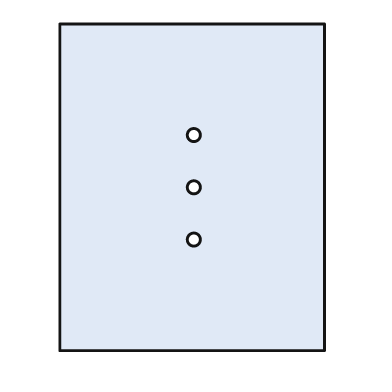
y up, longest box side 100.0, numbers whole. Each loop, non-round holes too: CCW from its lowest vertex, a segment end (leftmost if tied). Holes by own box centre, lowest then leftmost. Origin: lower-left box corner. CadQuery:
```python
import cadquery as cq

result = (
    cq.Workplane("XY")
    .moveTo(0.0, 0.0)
    .lineTo(81.0, 0.0)
    .lineTo(81.0, 100.0)
    .lineTo(0.0, 100.0)
    .close()
    .moveTo(41.0, 34.0)
    .circle(2.0)
    .moveTo(41.0, 50.0)
    .circle(2.0)
    .moveTo(41.0, 66.0)
    .circle(2.0)
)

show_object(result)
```